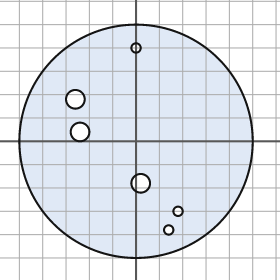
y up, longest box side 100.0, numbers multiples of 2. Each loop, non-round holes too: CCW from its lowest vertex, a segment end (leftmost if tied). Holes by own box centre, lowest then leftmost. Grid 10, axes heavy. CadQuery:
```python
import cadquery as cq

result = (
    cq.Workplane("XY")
    .moveTo(0.0, 0.0)
    .circle(50.0)
    .moveTo(14.0, -38.0)
    .circle(2.0)
    .moveTo(18.0, -30.0)
    .circle(2.0)
    .moveTo(2.0, -18.0)
    .circle(4.0)
    .moveTo(-24.0, 4.0)
    .circle(4.0)
    .moveTo(-26.0, 18.0)
    .circle(4.0)
    .moveTo(0.0, 40.0)
    .circle(2.0)
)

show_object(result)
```